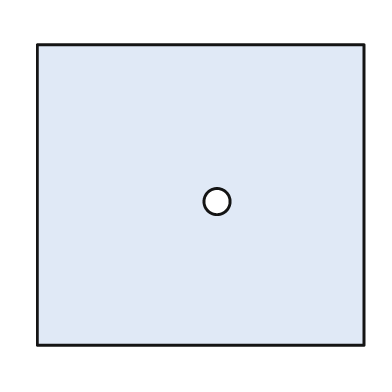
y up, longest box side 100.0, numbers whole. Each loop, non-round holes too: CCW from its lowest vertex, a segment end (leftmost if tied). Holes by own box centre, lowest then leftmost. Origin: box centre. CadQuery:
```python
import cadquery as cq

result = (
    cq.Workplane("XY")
    .moveTo(-50.0, -46.0)
    .lineTo(50.0, -46.0)
    .lineTo(50.0, 46.0)
    .lineTo(-50.0, 46.0)
    .close()
    .moveTo(5.0, -2.0)
    .circle(4.0)
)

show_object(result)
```